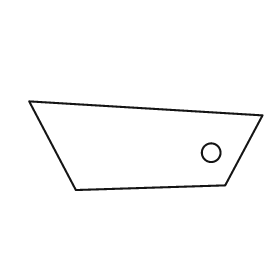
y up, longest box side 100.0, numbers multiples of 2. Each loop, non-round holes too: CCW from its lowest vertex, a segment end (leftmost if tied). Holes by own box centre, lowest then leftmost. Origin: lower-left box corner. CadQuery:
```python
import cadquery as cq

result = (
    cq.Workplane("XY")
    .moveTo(20.0, 0.0)
    .lineTo(84.0, 2.0)
    .lineTo(100.0, 32.0)
    .lineTo(0.0, 38.0)
    .close()
    .moveTo(78.0, 16.0)
    .circle(4.0)
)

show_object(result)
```